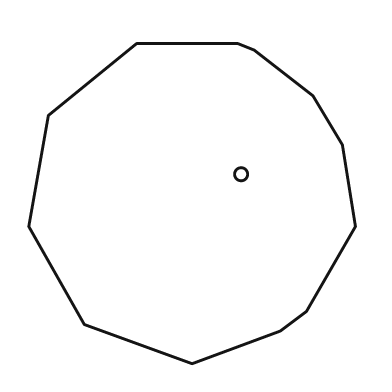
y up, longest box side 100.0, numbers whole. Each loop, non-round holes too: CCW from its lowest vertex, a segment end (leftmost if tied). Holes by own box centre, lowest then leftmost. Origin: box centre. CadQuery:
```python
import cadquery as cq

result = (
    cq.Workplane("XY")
    .moveTo(0.0, -49.0)
    .lineTo(27.0, -39.0)
    .lineTo(35.0, -33.0)
    .lineTo(50.0, -7.0)
    .lineTo(46.0, 18.0)
    .lineTo(37.0, 33.0)
    .lineTo(19.0, 47.0)
    .lineTo(14.0, 49.0)
    .lineTo(-17.0, 49.0)
    .lineTo(-44.0, 27.0)
    .lineTo(-50.0, -7.0)
    .lineTo(-33.0, -37.0)
    .close()
    .moveTo(15.0, 9.0)
    .circle(2.0)
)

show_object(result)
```